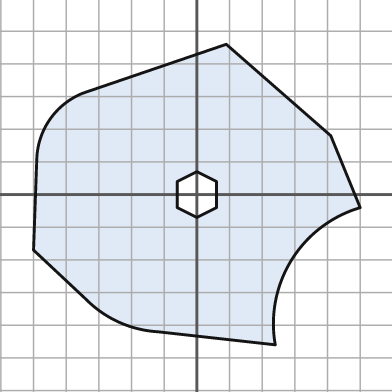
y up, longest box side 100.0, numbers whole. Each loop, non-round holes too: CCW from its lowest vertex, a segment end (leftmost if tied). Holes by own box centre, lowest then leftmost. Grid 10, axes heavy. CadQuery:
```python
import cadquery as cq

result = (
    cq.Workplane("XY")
    .moveTo(24.0, -46.0)
    .threePointArc((29.0, -20.0), (50.0, -4.0))
    .lineTo(41.0, 18.0)
    .lineTo(9.0, 46.0)
    .lineTo(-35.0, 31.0)
    .threePointArc((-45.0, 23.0), (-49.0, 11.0))
    .lineTo(-50.0, -17.0)
    .lineTo(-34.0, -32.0)
    .threePointArc((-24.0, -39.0), (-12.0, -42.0))
    .close()
    .moveTo(0.0, -7.0)
    .lineTo(6.0, -4.0)
    .lineTo(6.0, 4.0)
    .lineTo(0.0, 7.0)
    .lineTo(-6.0, 4.0)
    .lineTo(-6.0, -4.0)
    .close()
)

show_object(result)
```